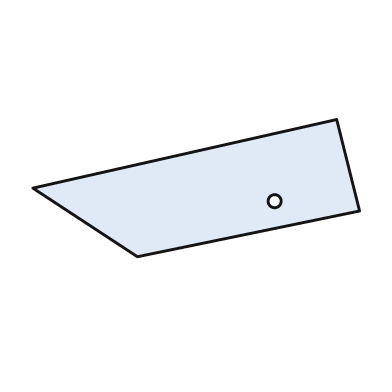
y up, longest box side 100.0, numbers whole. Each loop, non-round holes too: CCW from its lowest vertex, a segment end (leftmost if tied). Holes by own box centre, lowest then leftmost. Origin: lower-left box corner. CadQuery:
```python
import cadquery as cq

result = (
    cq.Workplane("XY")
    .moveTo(32.0, 0.0)
    .lineTo(100.0, 14.0)
    .lineTo(93.0, 42.0)
    .lineTo(0.0, 21.0)
    .close()
    .moveTo(74.0, 17.0)
    .circle(2.0)
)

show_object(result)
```